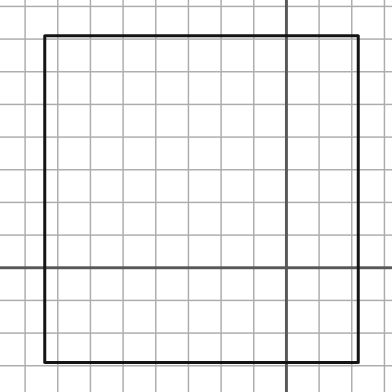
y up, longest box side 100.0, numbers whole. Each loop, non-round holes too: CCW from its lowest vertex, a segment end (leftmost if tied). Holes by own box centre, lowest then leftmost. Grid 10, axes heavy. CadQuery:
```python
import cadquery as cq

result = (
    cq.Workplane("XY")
    .moveTo(-74.0, -29.0)
    .lineTo(22.0, -29.0)
    .lineTo(22.0, 71.0)
    .lineTo(-74.0, 71.0)
    .close()
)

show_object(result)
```